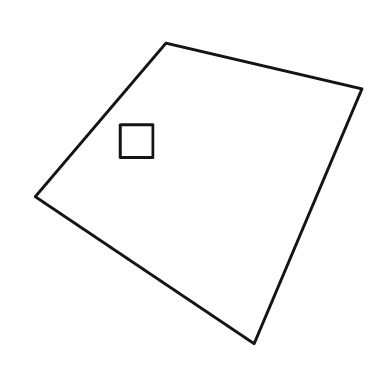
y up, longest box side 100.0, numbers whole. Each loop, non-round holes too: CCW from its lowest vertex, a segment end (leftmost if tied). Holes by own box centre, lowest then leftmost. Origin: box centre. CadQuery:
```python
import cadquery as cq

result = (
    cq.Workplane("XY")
    .moveTo(17.0, -46.0)
    .lineTo(50.0, 32.0)
    .lineTo(-10.0, 46.0)
    .lineTo(-50.0, -1.0)
    .close()
    .moveTo(-24.0, 11.0)
    .lineTo(-14.0, 11.0)
    .lineTo(-14.0, 21.0)
    .lineTo(-24.0, 21.0)
    .close()
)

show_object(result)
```